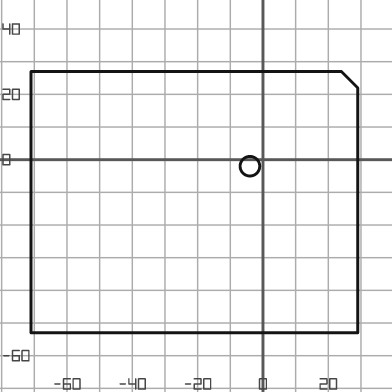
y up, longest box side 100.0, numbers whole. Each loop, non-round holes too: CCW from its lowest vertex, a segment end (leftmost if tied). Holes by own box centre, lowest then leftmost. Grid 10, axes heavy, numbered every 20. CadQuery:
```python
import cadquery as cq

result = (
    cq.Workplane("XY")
    .moveTo(-71.0, -53.0)
    .lineTo(29.0, -53.0)
    .lineTo(29.0, 22.0)
    .lineTo(24.0, 27.0)
    .lineTo(-71.0, 27.0)
    .close()
    .moveTo(-4.0, -2.0)
    .circle(3.0)
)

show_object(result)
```